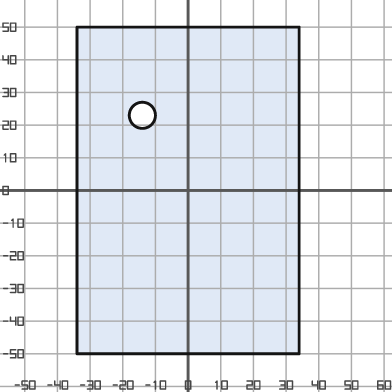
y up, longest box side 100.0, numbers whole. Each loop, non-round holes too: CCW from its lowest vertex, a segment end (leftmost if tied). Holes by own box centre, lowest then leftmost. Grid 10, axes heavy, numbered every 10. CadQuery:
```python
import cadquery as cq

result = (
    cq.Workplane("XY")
    .moveTo(-34.0, -50.0)
    .lineTo(34.0, -50.0)
    .lineTo(34.0, 50.0)
    .lineTo(-34.0, 50.0)
    .close()
    .moveTo(-14.0, 23.0)
    .circle(4.0)
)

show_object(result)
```